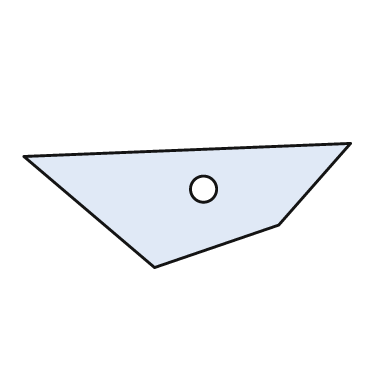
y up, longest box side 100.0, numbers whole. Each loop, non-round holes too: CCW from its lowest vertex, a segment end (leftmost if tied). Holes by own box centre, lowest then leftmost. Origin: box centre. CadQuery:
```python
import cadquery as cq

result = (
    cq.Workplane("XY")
    .moveTo(-10.0, -19.0)
    .lineTo(28.0, -6.0)
    .lineTo(50.0, 19.0)
    .lineTo(-50.0, 15.0)
    .close()
    .moveTo(5.0, 5.0)
    .circle(4.0)
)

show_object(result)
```